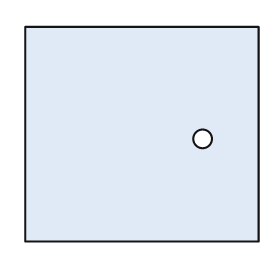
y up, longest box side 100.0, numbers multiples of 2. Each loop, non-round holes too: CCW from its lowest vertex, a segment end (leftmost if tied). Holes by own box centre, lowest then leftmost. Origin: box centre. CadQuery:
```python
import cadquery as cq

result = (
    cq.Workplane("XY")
    .moveTo(-50.0, -46.0)
    .lineTo(50.0, -46.0)
    .lineTo(50.0, 46.0)
    .lineTo(-50.0, 46.0)
    .close()
    .moveTo(26.0, -2.0)
    .circle(4.0)
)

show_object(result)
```